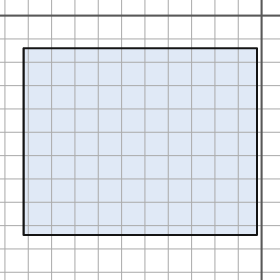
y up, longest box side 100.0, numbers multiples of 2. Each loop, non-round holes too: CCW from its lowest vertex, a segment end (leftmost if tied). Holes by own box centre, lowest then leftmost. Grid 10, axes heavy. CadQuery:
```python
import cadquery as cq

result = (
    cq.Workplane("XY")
    .moveTo(-102.0, -94.0)
    .lineTo(-2.0, -94.0)
    .lineTo(-2.0, -14.0)
    .lineTo(-102.0, -14.0)
    .close()
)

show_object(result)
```